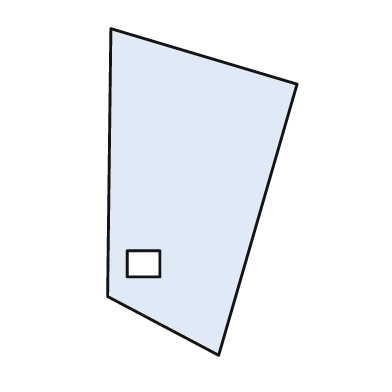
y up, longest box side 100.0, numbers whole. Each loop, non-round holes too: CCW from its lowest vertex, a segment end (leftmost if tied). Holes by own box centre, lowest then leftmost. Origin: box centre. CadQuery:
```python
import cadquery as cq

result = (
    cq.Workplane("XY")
    .moveTo(5.0, -50.0)
    .lineTo(29.0, 33.0)
    .lineTo(-28.0, 50.0)
    .lineTo(-29.0, -32.0)
    .close()
    .moveTo(-23.0, -26.0)
    .lineTo(-13.0, -26.0)
    .lineTo(-13.0, -18.0)
    .lineTo(-23.0, -18.0)
    .close()
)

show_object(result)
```